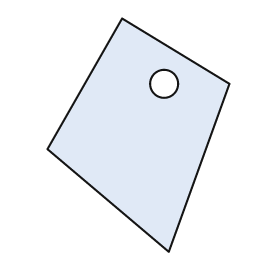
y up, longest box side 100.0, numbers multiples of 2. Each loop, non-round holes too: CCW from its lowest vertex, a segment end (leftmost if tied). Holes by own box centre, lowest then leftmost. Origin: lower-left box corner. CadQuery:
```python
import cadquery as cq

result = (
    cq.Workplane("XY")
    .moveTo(52.0, 0.0)
    .lineTo(78.0, 72.0)
    .lineTo(32.0, 100.0)
    .lineTo(0.0, 44.0)
    .close()
    .moveTo(50.0, 72.0)
    .circle(6.0)
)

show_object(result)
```